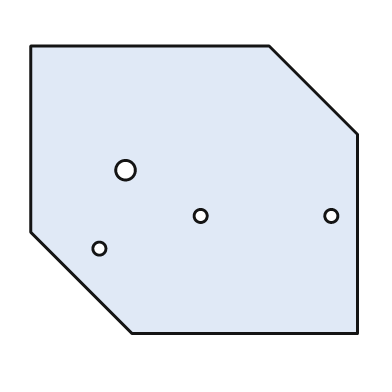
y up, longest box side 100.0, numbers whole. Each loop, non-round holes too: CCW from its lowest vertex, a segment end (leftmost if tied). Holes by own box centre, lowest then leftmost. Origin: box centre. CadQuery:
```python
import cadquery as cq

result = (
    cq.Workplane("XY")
    .moveTo(-19.0, -44.0)
    .lineTo(50.0, -44.0)
    .lineTo(50.0, 17.0)
    .lineTo(23.0, 44.0)
    .lineTo(-50.0, 44.0)
    .lineTo(-50.0, -13.0)
    .close()
    .moveTo(-29.0, -18.0)
    .circle(2.0)
    .moveTo(2.0, -8.0)
    .circle(2.0)
    .moveTo(42.0, -8.0)
    .circle(2.0)
    .moveTo(-21.0, 6.0)
    .circle(3.0)
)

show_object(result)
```